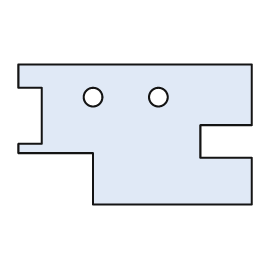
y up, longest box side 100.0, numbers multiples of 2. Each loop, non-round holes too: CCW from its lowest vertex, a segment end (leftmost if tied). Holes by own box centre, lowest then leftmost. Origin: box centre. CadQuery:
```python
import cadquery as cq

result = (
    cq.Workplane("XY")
    .moveTo(-18.0, -30.0)
    .lineTo(50.0, -30.0)
    .lineTo(50.0, -10.0)
    .lineTo(28.0, -10.0)
    .lineTo(28.0, 4.0)
    .lineTo(50.0, 4.0)
    .lineTo(50.0, 30.0)
    .lineTo(-50.0, 30.0)
    .lineTo(-50.0, 20.0)
    .lineTo(-40.0, 20.0)
    .lineTo(-40.0, -4.0)
    .lineTo(-50.0, -4.0)
    .lineTo(-50.0, -8.0)
    .lineTo(-18.0, -8.0)
    .close()
    .moveTo(-18.0, 16.0)
    .circle(4.0)
    .moveTo(10.0, 16.0)
    .circle(4.0)
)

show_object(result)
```